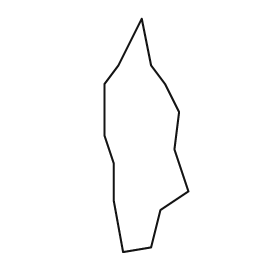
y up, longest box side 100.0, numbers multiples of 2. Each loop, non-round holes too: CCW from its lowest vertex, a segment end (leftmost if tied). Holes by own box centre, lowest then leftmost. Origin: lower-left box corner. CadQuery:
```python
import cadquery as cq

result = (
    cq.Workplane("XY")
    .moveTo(8.0, 0.0)
    .lineTo(20.0, 2.0)
    .lineTo(24.0, 18.0)
    .lineTo(36.0, 26.0)
    .lineTo(30.0, 44.0)
    .lineTo(32.0, 60.0)
    .lineTo(26.0, 72.0)
    .lineTo(20.0, 80.0)
    .lineTo(16.0, 100.0)
    .lineTo(6.0, 80.0)
    .lineTo(0.0, 72.0)
    .lineTo(0.0, 50.0)
    .lineTo(4.0, 38.0)
    .lineTo(4.0, 22.0)
    .close()
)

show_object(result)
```